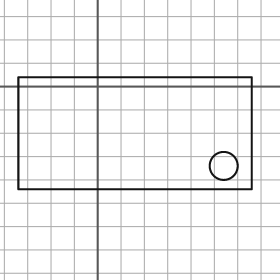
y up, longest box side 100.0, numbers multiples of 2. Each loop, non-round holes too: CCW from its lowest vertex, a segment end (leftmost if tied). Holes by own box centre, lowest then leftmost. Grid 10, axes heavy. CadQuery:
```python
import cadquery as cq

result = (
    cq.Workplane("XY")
    .moveTo(-34.0, -44.0)
    .lineTo(66.0, -44.0)
    .lineTo(66.0, 4.0)
    .lineTo(-34.0, 4.0)
    .close()
    .moveTo(54.0, -34.0)
    .circle(6.0)
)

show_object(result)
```